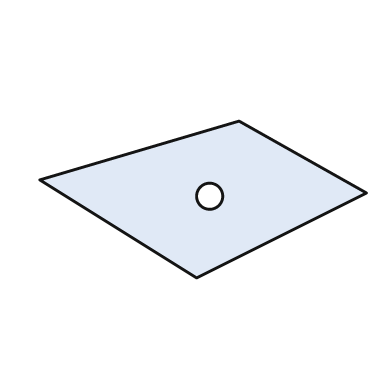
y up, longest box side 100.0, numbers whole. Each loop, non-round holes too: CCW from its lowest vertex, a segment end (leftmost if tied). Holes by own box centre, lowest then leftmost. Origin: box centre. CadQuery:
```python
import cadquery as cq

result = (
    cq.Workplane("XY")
    .moveTo(-2.0, -24.0)
    .lineTo(50.0, 2.0)
    .lineTo(11.0, 24.0)
    .lineTo(-50.0, 6.0)
    .close()
    .moveTo(2.0, 1.0)
    .circle(4.0)
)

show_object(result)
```